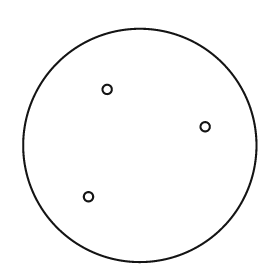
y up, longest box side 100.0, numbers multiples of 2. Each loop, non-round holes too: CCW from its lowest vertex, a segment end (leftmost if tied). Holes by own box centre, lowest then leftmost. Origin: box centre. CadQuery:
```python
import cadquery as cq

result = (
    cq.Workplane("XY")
    .moveTo(0.0, 0.0)
    .circle(50.0)
    .moveTo(-22.0, -22.0)
    .circle(2.0)
    .moveTo(28.0, 8.0)
    .circle(2.0)
    .moveTo(-14.0, 24.0)
    .circle(2.0)
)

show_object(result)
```